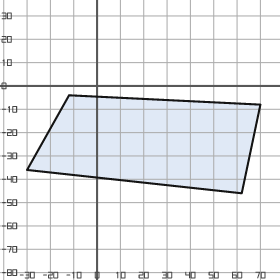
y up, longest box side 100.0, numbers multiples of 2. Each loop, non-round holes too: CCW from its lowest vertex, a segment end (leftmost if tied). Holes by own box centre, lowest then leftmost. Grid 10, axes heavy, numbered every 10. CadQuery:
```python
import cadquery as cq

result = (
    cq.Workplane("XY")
    .moveTo(62.0, -46.0)
    .lineTo(70.0, -8.0)
    .lineTo(-12.0, -4.0)
    .lineTo(-30.0, -36.0)
    .close()
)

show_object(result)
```